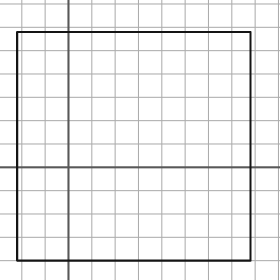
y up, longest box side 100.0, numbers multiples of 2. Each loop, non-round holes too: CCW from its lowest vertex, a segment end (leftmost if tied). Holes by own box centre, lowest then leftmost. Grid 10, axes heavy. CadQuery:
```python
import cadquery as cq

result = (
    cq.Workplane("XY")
    .moveTo(-22.0, -40.0)
    .lineTo(78.0, -40.0)
    .lineTo(78.0, 58.0)
    .lineTo(-22.0, 58.0)
    .close()
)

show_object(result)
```